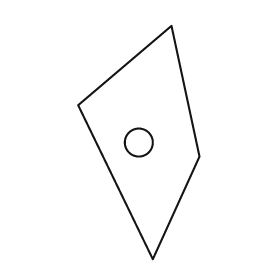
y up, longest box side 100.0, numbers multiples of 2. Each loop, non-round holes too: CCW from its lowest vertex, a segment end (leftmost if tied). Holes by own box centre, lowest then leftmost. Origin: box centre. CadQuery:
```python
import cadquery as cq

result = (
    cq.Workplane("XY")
    .moveTo(6.0, -50.0)
    .lineTo(26.0, -6.0)
    .lineTo(14.0, 50.0)
    .lineTo(-26.0, 16.0)
    .close()
    .moveTo(0.0, 0.0)
    .circle(6.0)
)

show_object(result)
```